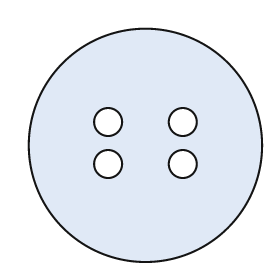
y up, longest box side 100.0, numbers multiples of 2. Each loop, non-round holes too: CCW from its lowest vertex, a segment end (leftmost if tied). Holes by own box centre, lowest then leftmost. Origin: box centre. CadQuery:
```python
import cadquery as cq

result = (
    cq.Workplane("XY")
    .moveTo(0.0, 0.0)
    .circle(50.0)
    .moveTo(-16.0, -8.0)
    .circle(6.0)
    .moveTo(16.0, -8.0)
    .circle(6.0)
    .moveTo(-16.0, 10.0)
    .circle(6.0)
    .moveTo(16.0, 10.0)
    .circle(6.0)
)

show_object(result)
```